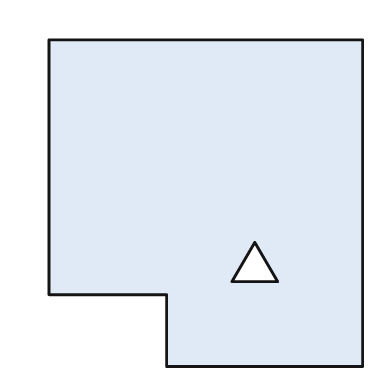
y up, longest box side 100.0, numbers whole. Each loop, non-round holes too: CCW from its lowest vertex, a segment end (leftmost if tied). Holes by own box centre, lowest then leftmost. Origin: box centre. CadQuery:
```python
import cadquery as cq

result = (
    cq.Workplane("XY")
    .moveTo(-12.0, -50.0)
    .lineTo(48.0, -50.0)
    .lineTo(48.0, 50.0)
    .lineTo(-48.0, 50.0)
    .lineTo(-48.0, -28.0)
    .lineTo(-12.0, -28.0)
    .close()
    .moveTo(8.0, -24.0)
    .lineTo(22.0, -24.0)
    .lineTo(15.0, -12.0)
    .close()
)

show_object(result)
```